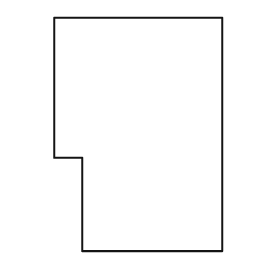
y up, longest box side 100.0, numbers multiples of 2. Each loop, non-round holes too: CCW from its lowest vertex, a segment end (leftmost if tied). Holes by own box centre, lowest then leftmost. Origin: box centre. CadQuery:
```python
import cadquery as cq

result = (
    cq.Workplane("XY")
    .moveTo(-24.0, -50.0)
    .lineTo(36.0, -50.0)
    .lineTo(36.0, 50.0)
    .lineTo(-36.0, 50.0)
    .lineTo(-36.0, -10.0)
    .lineTo(-24.0, -10.0)
    .close()
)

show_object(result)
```